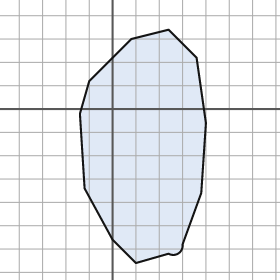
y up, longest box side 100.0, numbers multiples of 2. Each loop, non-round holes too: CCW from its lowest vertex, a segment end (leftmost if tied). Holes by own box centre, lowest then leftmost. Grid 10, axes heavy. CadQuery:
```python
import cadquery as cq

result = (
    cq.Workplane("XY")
    .moveTo(10.0, -66.0)
    .lineTo(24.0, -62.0)
    .threePointArc((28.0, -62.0), (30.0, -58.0))
    .lineTo(38.0, -36.0)
    .lineTo(40.0, -6.0)
    .lineTo(36.0, 22.0)
    .lineTo(24.0, 34.0)
    .lineTo(8.0, 30.0)
    .lineTo(-10.0, 12.0)
    .lineTo(-14.0, -2.0)
    .lineTo(-12.0, -34.0)
    .lineTo(0.0, -56.0)
    .close()
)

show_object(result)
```